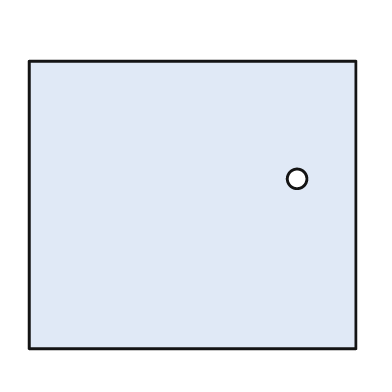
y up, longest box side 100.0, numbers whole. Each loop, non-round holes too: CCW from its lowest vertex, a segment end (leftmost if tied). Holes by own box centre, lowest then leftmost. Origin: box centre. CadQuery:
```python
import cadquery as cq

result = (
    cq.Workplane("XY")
    .moveTo(-50.0, -44.0)
    .lineTo(50.0, -44.0)
    .lineTo(50.0, 44.0)
    .lineTo(-50.0, 44.0)
    .close()
    .moveTo(32.0, 8.0)
    .circle(3.0)
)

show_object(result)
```